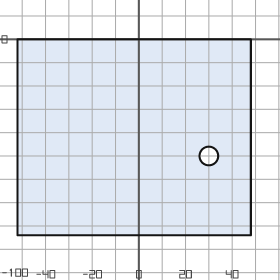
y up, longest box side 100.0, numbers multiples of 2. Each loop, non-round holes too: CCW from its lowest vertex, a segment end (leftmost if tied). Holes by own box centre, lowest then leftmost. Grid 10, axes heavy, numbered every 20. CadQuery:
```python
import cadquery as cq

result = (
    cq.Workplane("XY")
    .moveTo(-52.0, -84.0)
    .lineTo(48.0, -84.0)
    .lineTo(48.0, 0.0)
    .lineTo(-52.0, 0.0)
    .close()
    .moveTo(30.0, -50.0)
    .circle(4.0)
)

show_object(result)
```